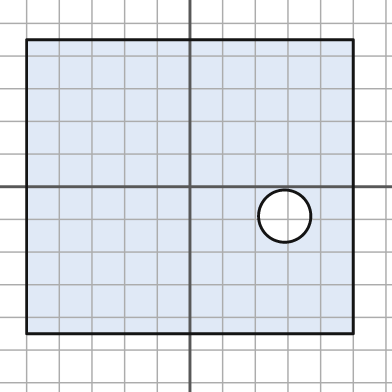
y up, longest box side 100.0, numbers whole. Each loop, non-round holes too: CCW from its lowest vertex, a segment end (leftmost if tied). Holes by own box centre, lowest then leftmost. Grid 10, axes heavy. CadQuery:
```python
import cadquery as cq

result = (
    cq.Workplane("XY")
    .moveTo(-50.0, -45.0)
    .lineTo(50.0, -45.0)
    .lineTo(50.0, 45.0)
    .lineTo(-50.0, 45.0)
    .close()
    .moveTo(29.0, -9.0)
    .circle(8.0)
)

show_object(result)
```